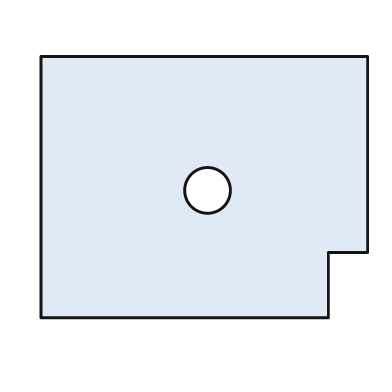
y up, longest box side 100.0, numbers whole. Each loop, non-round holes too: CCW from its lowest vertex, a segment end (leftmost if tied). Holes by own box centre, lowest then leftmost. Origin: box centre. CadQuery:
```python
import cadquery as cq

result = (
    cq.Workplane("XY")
    .moveTo(-50.0, -40.0)
    .lineTo(38.0, -40.0)
    .lineTo(38.0, -20.0)
    .lineTo(50.0, -20.0)
    .lineTo(50.0, 40.0)
    .lineTo(-50.0, 40.0)
    .close()
    .moveTo(1.0, -1.0)
    .circle(7.0)
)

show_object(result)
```